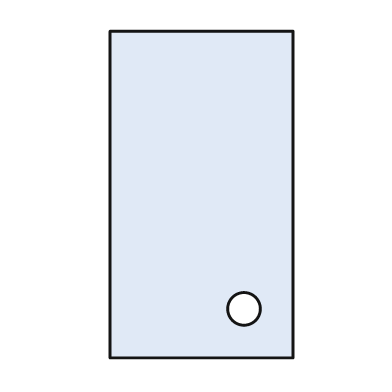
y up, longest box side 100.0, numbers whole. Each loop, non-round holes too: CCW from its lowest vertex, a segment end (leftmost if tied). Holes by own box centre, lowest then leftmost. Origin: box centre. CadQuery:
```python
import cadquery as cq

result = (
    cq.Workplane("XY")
    .moveTo(-28.0, -50.0)
    .lineTo(28.0, -50.0)
    .lineTo(28.0, 50.0)
    .lineTo(-28.0, 50.0)
    .close()
    .moveTo(13.0, -35.0)
    .circle(5.0)
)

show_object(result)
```